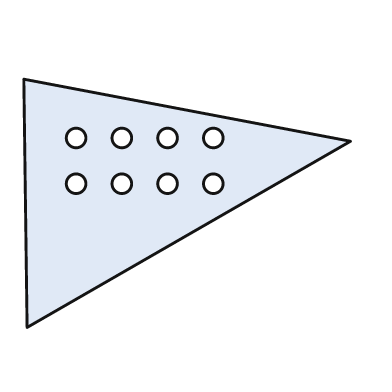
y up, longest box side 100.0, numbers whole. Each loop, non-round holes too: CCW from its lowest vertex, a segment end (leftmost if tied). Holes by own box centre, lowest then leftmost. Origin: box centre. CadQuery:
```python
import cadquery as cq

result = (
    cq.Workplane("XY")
    .moveTo(-49.0, -38.0)
    .lineTo(50.0, 19.0)
    .lineTo(-50.0, 38.0)
    .close()
    .moveTo(-34.0, 6.0)
    .circle(3.0)
    .moveTo(-20.0, 6.0)
    .circle(3.0)
    .moveTo(-6.0, 6.0)
    .circle(3.0)
    .moveTo(8.0, 6.0)
    .circle(3.0)
    .moveTo(-34.0, 20.0)
    .circle(3.0)
    .moveTo(-20.0, 20.0)
    .circle(3.0)
    .moveTo(-6.0, 20.0)
    .circle(3.0)
    .moveTo(8.0, 20.0)
    .circle(3.0)
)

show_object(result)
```